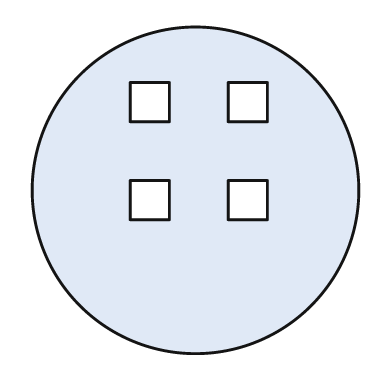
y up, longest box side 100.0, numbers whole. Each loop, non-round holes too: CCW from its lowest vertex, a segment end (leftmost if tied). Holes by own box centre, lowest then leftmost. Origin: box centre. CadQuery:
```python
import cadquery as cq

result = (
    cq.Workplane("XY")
    .moveTo(0.0, 0.0)
    .circle(50.0)
    .moveTo(-20.0, -9.0)
    .lineTo(-8.0, -9.0)
    .lineTo(-8.0, 3.0)
    .lineTo(-20.0, 3.0)
    .close()
    .moveTo(10.0, -9.0)
    .lineTo(22.0, -9.0)
    .lineTo(22.0, 3.0)
    .lineTo(10.0, 3.0)
    .close()
    .moveTo(-20.0, 21.0)
    .lineTo(-8.0, 21.0)
    .lineTo(-8.0, 33.0)
    .lineTo(-20.0, 33.0)
    .close()
    .moveTo(10.0, 21.0)
    .lineTo(22.0, 21.0)
    .lineTo(22.0, 33.0)
    .lineTo(10.0, 33.0)
    .close()
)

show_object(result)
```